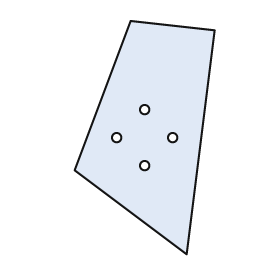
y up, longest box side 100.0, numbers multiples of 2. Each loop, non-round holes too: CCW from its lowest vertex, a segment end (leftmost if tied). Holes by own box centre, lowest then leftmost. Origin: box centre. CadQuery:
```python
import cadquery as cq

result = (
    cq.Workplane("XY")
    .moveTo(18.0, -50.0)
    .lineTo(30.0, 46.0)
    .lineTo(-6.0, 50.0)
    .lineTo(-30.0, -14.0)
    .close()
    .moveTo(0.0, -12.0)
    .circle(2.0)
    .moveTo(-12.0, 0.0)
    .circle(2.0)
    .moveTo(12.0, 0.0)
    .circle(2.0)
    .moveTo(0.0, 12.0)
    .circle(2.0)
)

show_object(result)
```